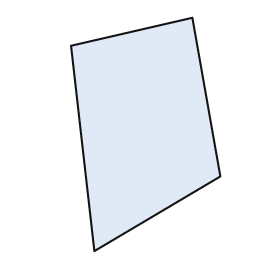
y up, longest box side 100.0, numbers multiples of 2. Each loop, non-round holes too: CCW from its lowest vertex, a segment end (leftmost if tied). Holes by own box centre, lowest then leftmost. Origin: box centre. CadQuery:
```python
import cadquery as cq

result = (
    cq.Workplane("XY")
    .moveTo(-22.0, -50.0)
    .lineTo(32.0, -18.0)
    .lineTo(20.0, 50.0)
    .lineTo(-32.0, 38.0)
    .close()
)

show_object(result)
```